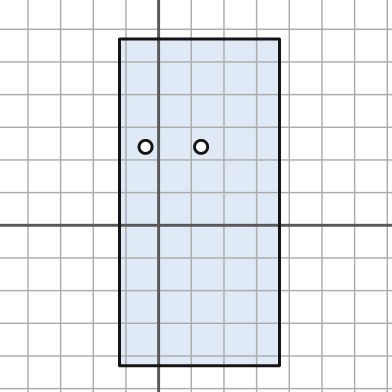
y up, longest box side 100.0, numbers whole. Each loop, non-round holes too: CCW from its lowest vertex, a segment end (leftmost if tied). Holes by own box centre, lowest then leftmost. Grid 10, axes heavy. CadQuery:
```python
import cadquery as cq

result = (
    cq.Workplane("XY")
    .moveTo(-12.0, -43.0)
    .lineTo(37.0, -43.0)
    .lineTo(37.0, 57.0)
    .lineTo(-12.0, 57.0)
    .close()
    .moveTo(-4.0, 24.0)
    .circle(2.0)
    .moveTo(13.0, 24.0)
    .circle(2.0)
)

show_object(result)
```